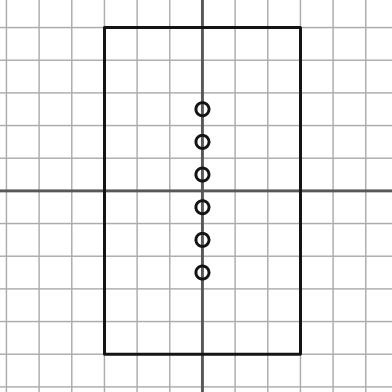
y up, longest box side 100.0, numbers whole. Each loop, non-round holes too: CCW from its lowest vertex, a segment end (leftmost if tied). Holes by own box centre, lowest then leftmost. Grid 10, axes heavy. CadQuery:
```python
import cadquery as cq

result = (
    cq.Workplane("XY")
    .moveTo(-30.0, -50.0)
    .lineTo(30.0, -50.0)
    .lineTo(30.0, 50.0)
    .lineTo(-30.0, 50.0)
    .close()
    .moveTo(0.0, -25.0)
    .circle(2.0)
    .moveTo(0.0, -15.0)
    .circle(2.0)
    .moveTo(0.0, -5.0)
    .circle(2.0)
    .moveTo(0.0, 5.0)
    .circle(2.0)
    .moveTo(0.0, 15.0)
    .circle(2.0)
    .moveTo(0.0, 25.0)
    .circle(2.0)
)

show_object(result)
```